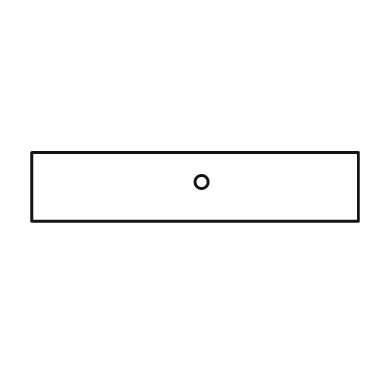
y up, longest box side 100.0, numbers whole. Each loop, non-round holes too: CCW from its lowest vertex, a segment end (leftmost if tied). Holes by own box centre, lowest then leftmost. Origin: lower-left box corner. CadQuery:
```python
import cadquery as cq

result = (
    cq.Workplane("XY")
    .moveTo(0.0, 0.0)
    .lineTo(100.0, 0.0)
    .lineTo(100.0, 21.0)
    .lineTo(0.0, 21.0)
    .close()
    .moveTo(52.0, 12.0)
    .circle(2.0)
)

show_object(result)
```